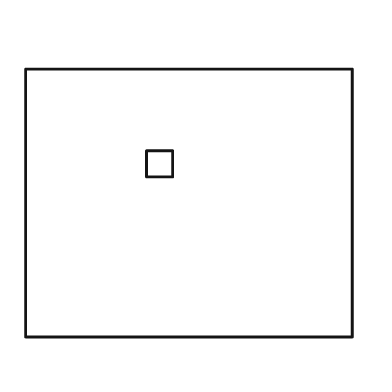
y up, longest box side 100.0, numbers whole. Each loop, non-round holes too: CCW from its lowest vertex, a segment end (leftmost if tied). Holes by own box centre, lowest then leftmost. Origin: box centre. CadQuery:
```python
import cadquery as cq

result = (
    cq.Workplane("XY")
    .moveTo(-50.0, -41.0)
    .lineTo(50.0, -41.0)
    .lineTo(50.0, 41.0)
    .lineTo(-50.0, 41.0)
    .close()
    .moveTo(-13.0, 8.0)
    .lineTo(-5.0, 8.0)
    .lineTo(-5.0, 16.0)
    .lineTo(-13.0, 16.0)
    .close()
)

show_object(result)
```